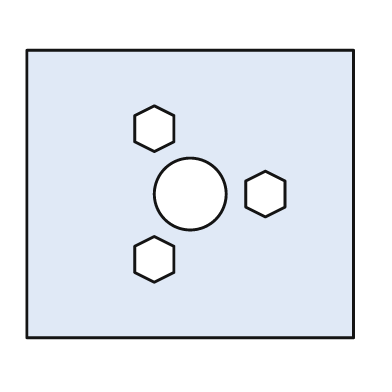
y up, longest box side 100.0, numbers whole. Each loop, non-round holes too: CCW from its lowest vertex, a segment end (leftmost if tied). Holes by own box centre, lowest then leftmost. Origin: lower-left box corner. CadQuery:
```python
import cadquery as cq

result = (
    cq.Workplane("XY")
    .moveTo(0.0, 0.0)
    .lineTo(100.0, 0.0)
    .lineTo(100.0, 88.0)
    .lineTo(0.0, 88.0)
    .close()
    .moveTo(39.0, 17.0)
    .lineTo(45.0, 20.0)
    .lineTo(45.0, 28.0)
    .lineTo(39.0, 31.0)
    .lineTo(33.0, 28.0)
    .lineTo(33.0, 20.0)
    .close()
    .moveTo(50.0, 44.0)
    .circle(11.0)
    .moveTo(73.0, 37.0)
    .lineTo(79.0, 40.0)
    .lineTo(79.0, 48.0)
    .lineTo(73.0, 51.0)
    .lineTo(67.0, 48.0)
    .lineTo(67.0, 40.0)
    .close()
    .moveTo(39.0, 57.0)
    .lineTo(45.0, 60.0)
    .lineTo(45.0, 68.0)
    .lineTo(39.0, 71.0)
    .lineTo(33.0, 68.0)
    .lineTo(33.0, 60.0)
    .close()
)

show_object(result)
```